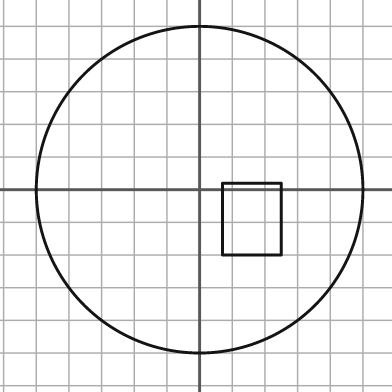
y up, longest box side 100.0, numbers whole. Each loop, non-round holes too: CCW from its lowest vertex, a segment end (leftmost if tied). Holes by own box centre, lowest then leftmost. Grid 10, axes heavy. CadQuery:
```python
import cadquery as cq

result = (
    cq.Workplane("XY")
    .moveTo(0.0, 0.0)
    .circle(50.0)
    .moveTo(7.0, -20.0)
    .lineTo(25.0, -20.0)
    .lineTo(25.0, 2.0)
    .lineTo(7.0, 2.0)
    .close()
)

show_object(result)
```